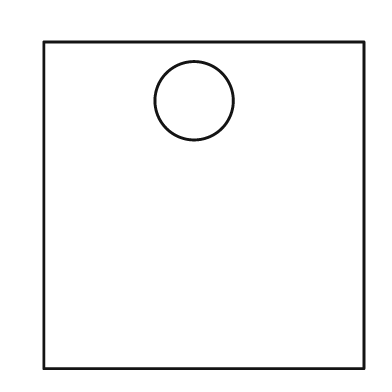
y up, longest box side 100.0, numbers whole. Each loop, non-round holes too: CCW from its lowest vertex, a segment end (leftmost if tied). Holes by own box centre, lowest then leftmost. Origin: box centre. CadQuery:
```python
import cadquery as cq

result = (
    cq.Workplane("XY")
    .moveTo(-49.0, -50.0)
    .lineTo(49.0, -50.0)
    .lineTo(49.0, 50.0)
    .lineTo(-49.0, 50.0)
    .close()
    .moveTo(-3.0, 32.0)
    .circle(12.0)
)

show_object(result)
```